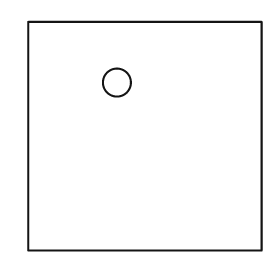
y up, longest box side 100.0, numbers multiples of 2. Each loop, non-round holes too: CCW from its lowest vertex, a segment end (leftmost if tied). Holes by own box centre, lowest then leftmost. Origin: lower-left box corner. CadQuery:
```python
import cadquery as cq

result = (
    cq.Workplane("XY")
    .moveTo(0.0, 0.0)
    .lineTo(100.0, 0.0)
    .lineTo(100.0, 98.0)
    .lineTo(0.0, 98.0)
    .close()
    .moveTo(38.0, 72.0)
    .circle(6.0)
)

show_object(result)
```